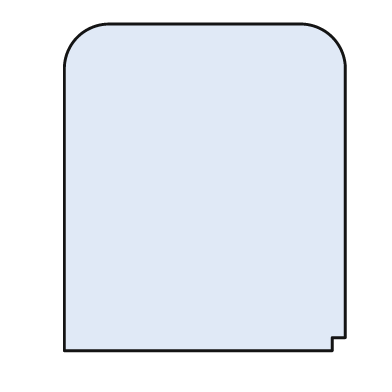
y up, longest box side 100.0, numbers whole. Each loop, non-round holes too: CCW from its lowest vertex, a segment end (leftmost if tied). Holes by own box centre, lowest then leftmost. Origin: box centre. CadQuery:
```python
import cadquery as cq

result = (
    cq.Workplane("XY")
    .moveTo(-43.0, -50.0)
    .lineTo(39.0, -50.0)
    .lineTo(39.0, -46.0)
    .lineTo(43.0, -46.0)
    .lineTo(43.0, 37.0)
    .threePointArc((39.0, 46.0), (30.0, 50.0))
    .lineTo(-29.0, 50.0)
    .threePointArc((-39.0, 46.0), (-43.0, 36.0))
    .close()
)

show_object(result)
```